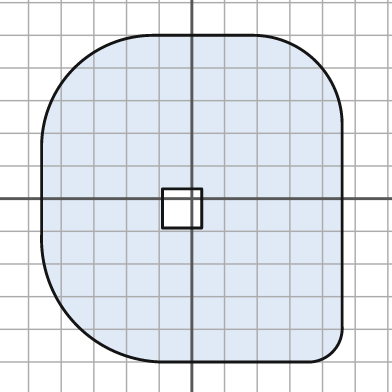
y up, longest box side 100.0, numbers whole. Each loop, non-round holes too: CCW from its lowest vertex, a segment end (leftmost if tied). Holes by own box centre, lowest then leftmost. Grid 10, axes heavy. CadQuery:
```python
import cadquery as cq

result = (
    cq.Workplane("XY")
    .moveTo(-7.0, -50.0)
    .lineTo(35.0, -50.0)
    .threePointArc((43.0, -47.0), (46.0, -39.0))
    .lineTo(46.0, 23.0)
    .threePointArc((38.0, 42.0), (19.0, 50.0))
    .lineTo(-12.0, 50.0)
    .threePointArc((-36.0, 40.0), (-46.0, 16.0))
    .lineTo(-46.0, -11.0)
    .threePointArc((-35.0, -39.0), (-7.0, -50.0))
    .close()
    .moveTo(-9.0, -9.0)
    .lineTo(3.0, -9.0)
    .lineTo(3.0, 3.0)
    .lineTo(-9.0, 3.0)
    .close()
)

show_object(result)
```